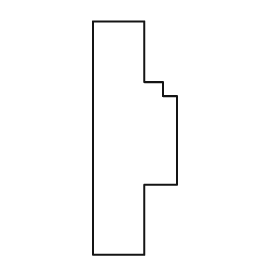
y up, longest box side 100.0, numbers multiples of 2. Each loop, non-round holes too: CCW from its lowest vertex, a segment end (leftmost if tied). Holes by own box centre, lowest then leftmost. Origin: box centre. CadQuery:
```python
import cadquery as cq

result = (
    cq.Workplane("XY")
    .moveTo(-18.0, -50.0)
    .lineTo(4.0, -50.0)
    .lineTo(4.0, -20.0)
    .lineTo(18.0, -20.0)
    .lineTo(18.0, 18.0)
    .lineTo(12.0, 18.0)
    .lineTo(12.0, 24.0)
    .lineTo(4.0, 24.0)
    .lineTo(4.0, 50.0)
    .lineTo(-18.0, 50.0)
    .close()
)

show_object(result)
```